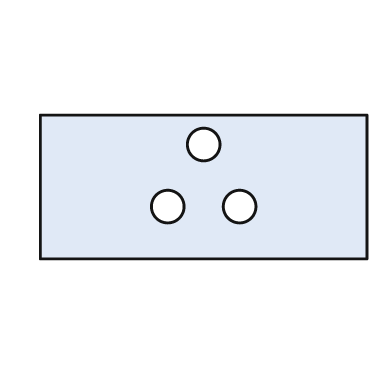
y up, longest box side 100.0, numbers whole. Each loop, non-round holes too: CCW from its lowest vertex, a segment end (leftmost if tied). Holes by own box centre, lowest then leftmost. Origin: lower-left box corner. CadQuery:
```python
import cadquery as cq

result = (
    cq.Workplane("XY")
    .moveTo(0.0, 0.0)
    .lineTo(100.0, 0.0)
    .lineTo(100.0, 44.0)
    .lineTo(0.0, 44.0)
    .close()
    .moveTo(39.0, 16.0)
    .circle(5.0)
    .moveTo(61.0, 16.0)
    .circle(5.0)
    .moveTo(50.0, 35.0)
    .circle(5.0)
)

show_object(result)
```